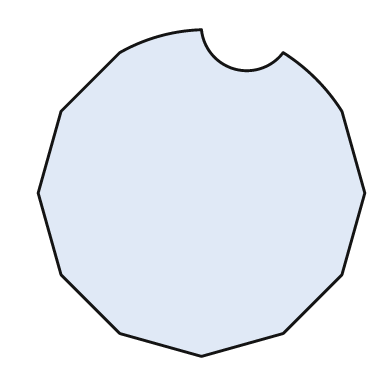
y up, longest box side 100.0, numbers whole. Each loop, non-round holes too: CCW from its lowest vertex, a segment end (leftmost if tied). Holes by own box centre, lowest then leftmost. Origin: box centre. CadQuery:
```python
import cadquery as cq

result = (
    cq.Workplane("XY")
    .moveTo(0.0, -50.0)
    .lineTo(25.0, -43.0)
    .lineTo(43.0, -25.0)
    .lineTo(50.0, 0.0)
    .lineTo(43.0, 25.0)
    .threePointArc((35.0, 35.0), (25.0, 43.0))
    .threePointArc((10.0, 38.0), (0.0, 50.0))
    .threePointArc((-13.0, 48.0), (-25.0, 43.0))
    .lineTo(-43.0, 25.0)
    .lineTo(-50.0, 0.0)
    .lineTo(-43.0, -25.0)
    .lineTo(-25.0, -43.0)
    .close()
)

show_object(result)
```